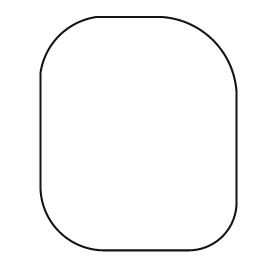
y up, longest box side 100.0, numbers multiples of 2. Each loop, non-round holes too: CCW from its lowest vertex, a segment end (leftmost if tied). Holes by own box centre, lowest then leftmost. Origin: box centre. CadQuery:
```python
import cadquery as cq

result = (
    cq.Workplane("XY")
    .moveTo(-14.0, -50.0)
    .lineTo(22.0, -50.0)
    .threePointArc((36.0, -44.0), (42.0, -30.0))
    .lineTo(42.0, 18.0)
    .threePointArc((32.0, 40.0), (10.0, 50.0))
    .lineTo(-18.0, 50.0)
    .threePointArc((-34.0, 42.0), (-42.0, 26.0))
    .lineTo(-42.0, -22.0)
    .threePointArc((-34.0, -42.0), (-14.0, -50.0))
    .close()
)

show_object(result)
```